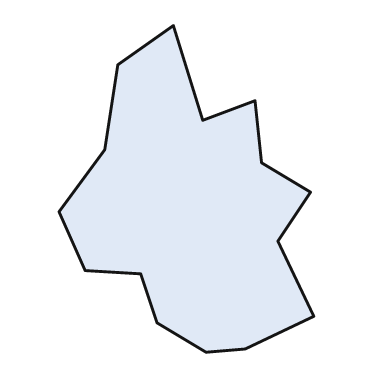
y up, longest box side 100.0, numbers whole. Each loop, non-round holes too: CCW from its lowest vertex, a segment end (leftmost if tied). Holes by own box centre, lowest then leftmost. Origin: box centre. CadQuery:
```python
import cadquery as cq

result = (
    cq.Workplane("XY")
    .moveTo(6.0, -50.0)
    .lineTo(18.0, -49.0)
    .lineTo(39.0, -39.0)
    .lineTo(28.0, -16.0)
    .lineTo(38.0, -1.0)
    .lineTo(23.0, 8.0)
    .lineTo(21.0, 27.0)
    .lineTo(5.0, 21.0)
    .lineTo(-4.0, 50.0)
    .lineTo(-21.0, 38.0)
    .lineTo(-25.0, 12.0)
    .lineTo(-39.0, -7.0)
    .lineTo(-31.0, -25.0)
    .lineTo(-14.0, -26.0)
    .lineTo(-9.0, -41.0)
    .close()
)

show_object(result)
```